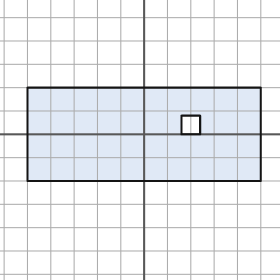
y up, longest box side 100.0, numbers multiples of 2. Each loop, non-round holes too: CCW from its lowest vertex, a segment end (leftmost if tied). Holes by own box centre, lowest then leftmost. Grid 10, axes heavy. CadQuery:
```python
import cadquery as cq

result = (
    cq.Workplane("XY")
    .moveTo(-50.0, -20.0)
    .lineTo(50.0, -20.0)
    .lineTo(50.0, 20.0)
    .lineTo(-50.0, 20.0)
    .close()
    .moveTo(16.0, 0.0)
    .lineTo(24.0, 0.0)
    .lineTo(24.0, 8.0)
    .lineTo(16.0, 8.0)
    .close()
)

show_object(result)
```